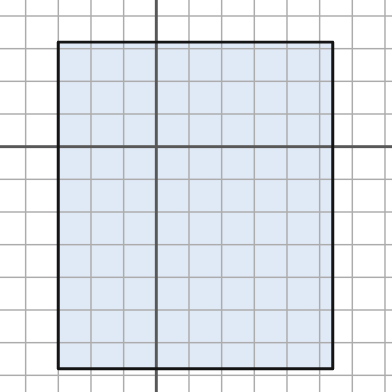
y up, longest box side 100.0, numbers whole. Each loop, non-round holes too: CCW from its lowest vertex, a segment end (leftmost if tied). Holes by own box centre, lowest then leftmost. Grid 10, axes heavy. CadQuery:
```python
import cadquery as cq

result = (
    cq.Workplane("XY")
    .moveTo(-30.0, -68.0)
    .lineTo(54.0, -68.0)
    .lineTo(54.0, 32.0)
    .lineTo(-30.0, 32.0)
    .close()
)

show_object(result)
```